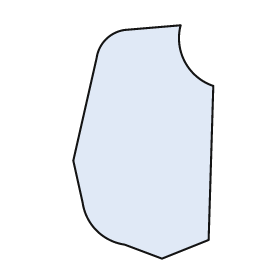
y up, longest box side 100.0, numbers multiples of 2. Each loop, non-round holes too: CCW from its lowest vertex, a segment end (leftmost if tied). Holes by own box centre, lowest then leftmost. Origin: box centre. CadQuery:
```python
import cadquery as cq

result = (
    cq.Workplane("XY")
    .moveTo(8.0, -50.0)
    .lineTo(28.0, -42.0)
    .lineTo(30.0, 24.0)
    .threePointArc((18.0, 34.0), (16.0, 50.0))
    .lineTo(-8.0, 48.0)
    .threePointArc((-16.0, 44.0), (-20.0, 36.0))
    .lineTo(-30.0, -8.0)
    .lineTo(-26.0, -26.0)
    .threePointArc((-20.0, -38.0), (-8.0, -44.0))
    .close()
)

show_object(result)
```